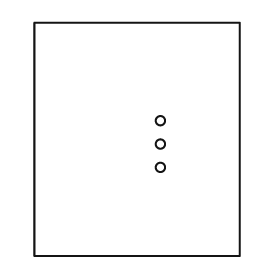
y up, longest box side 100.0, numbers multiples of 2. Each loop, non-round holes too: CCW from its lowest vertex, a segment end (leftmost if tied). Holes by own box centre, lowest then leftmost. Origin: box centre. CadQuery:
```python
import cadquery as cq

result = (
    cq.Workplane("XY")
    .moveTo(-44.0, -50.0)
    .lineTo(44.0, -50.0)
    .lineTo(44.0, 50.0)
    .lineTo(-44.0, 50.0)
    .close()
    .moveTo(10.0, -12.0)
    .circle(2.0)
    .moveTo(10.0, -2.0)
    .circle(2.0)
    .moveTo(10.0, 8.0)
    .circle(2.0)
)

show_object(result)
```